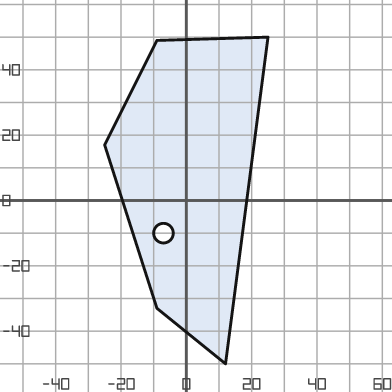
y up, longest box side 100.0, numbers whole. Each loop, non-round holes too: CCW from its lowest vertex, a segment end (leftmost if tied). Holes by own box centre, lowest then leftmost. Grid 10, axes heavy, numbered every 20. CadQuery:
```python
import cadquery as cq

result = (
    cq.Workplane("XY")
    .moveTo(12.0, -50.0)
    .lineTo(25.0, 50.0)
    .lineTo(-9.0, 49.0)
    .lineTo(-25.0, 17.0)
    .lineTo(-9.0, -33.0)
    .close()
    .moveTo(-7.0, -10.0)
    .circle(3.0)
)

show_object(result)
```